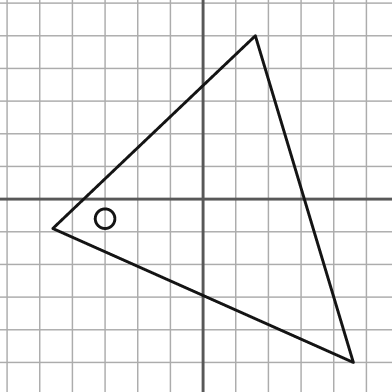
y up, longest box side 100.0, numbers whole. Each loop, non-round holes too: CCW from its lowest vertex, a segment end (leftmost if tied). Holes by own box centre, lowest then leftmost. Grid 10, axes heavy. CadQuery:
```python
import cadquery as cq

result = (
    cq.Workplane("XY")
    .moveTo(46.0, -50.0)
    .lineTo(16.0, 50.0)
    .lineTo(-46.0, -9.0)
    .close()
    .moveTo(-30.0, -6.0)
    .circle(3.0)
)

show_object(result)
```